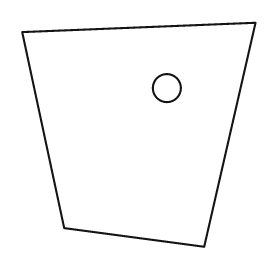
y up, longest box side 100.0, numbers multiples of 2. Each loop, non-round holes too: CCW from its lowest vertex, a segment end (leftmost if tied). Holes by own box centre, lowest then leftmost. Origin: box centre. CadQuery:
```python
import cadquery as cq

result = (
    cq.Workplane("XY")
    .moveTo(28.0, -48.0)
    .lineTo(50.0, 48.0)
    .lineTo(-50.0, 44.0)
    .lineTo(-32.0, -40.0)
    .close()
    .moveTo(12.0, 20.0)
    .circle(6.0)
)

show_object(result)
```